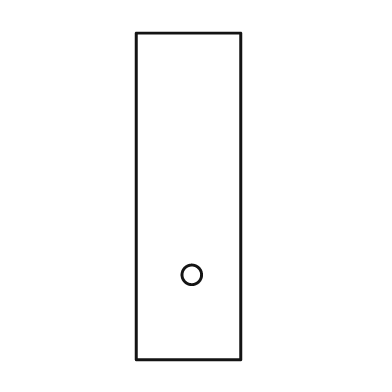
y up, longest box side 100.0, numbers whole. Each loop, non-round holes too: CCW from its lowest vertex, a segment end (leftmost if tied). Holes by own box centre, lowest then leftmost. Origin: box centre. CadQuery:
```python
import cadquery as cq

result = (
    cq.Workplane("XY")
    .moveTo(-16.0, -50.0)
    .lineTo(16.0, -50.0)
    .lineTo(16.0, 50.0)
    .lineTo(-16.0, 50.0)
    .close()
    .moveTo(1.0, -24.0)
    .circle(3.0)
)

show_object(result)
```